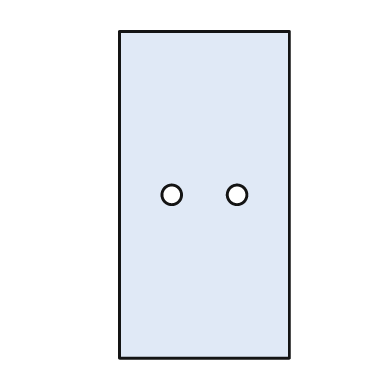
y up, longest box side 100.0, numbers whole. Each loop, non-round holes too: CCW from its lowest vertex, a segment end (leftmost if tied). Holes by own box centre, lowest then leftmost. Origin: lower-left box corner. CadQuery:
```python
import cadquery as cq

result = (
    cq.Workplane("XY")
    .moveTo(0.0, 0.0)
    .lineTo(52.0, 0.0)
    .lineTo(52.0, 100.0)
    .lineTo(0.0, 100.0)
    .close()
    .moveTo(16.0, 50.0)
    .circle(3.0)
    .moveTo(36.0, 50.0)
    .circle(3.0)
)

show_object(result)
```